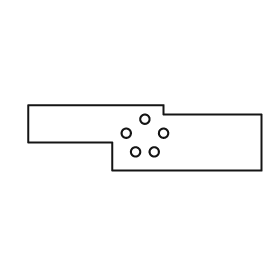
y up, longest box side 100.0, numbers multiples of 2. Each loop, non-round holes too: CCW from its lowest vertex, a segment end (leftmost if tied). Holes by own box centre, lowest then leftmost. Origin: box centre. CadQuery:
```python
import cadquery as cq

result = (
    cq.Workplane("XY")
    .moveTo(-14.0, -14.0)
    .lineTo(50.0, -14.0)
    .lineTo(50.0, 10.0)
    .lineTo(8.0, 10.0)
    .lineTo(8.0, 14.0)
    .lineTo(-50.0, 14.0)
    .lineTo(-50.0, -2.0)
    .lineTo(-14.0, -2.0)
    .close()
    .moveTo(-4.0, -6.0)
    .circle(2.0)
    .moveTo(4.0, -6.0)
    .circle(2.0)
    .moveTo(-8.0, 2.0)
    .circle(2.0)
    .moveTo(8.0, 2.0)
    .circle(2.0)
    .moveTo(0.0, 8.0)
    .circle(2.0)
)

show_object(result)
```